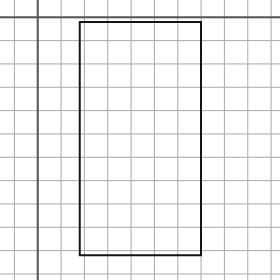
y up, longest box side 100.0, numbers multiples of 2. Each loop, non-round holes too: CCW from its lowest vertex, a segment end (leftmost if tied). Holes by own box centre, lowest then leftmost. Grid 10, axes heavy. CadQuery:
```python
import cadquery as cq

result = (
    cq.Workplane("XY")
    .moveTo(18.0, -102.0)
    .lineTo(70.0, -102.0)
    .lineTo(70.0, -2.0)
    .lineTo(18.0, -2.0)
    .close()
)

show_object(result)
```